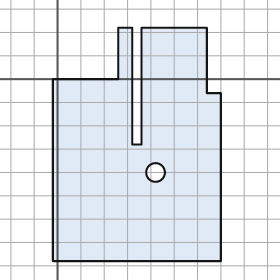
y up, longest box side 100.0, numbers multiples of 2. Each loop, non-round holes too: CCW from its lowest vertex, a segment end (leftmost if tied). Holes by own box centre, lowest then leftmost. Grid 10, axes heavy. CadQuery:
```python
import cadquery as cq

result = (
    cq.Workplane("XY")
    .moveTo(-2.0, -78.0)
    .lineTo(70.0, -78.0)
    .lineTo(70.0, -6.0)
    .lineTo(64.0, -6.0)
    .lineTo(64.0, 22.0)
    .lineTo(36.0, 22.0)
    .lineTo(36.0, -28.0)
    .lineTo(32.0, -28.0)
    .lineTo(32.0, 22.0)
    .lineTo(26.0, 22.0)
    .lineTo(26.0, 0.0)
    .lineTo(-2.0, 0.0)
    .close()
    .moveTo(42.0, -40.0)
    .circle(4.0)
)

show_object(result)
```